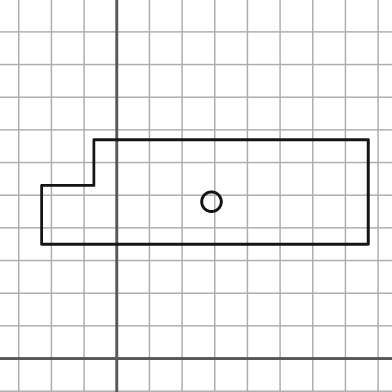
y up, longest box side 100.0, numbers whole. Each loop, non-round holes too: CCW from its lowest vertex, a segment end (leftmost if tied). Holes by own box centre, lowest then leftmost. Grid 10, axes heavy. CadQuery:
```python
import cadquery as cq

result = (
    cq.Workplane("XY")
    .moveTo(-23.0, 35.0)
    .lineTo(77.0, 35.0)
    .lineTo(77.0, 67.0)
    .lineTo(-7.0, 67.0)
    .lineTo(-7.0, 53.0)
    .lineTo(-23.0, 53.0)
    .close()
    .moveTo(29.0, 48.0)
    .circle(3.0)
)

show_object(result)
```